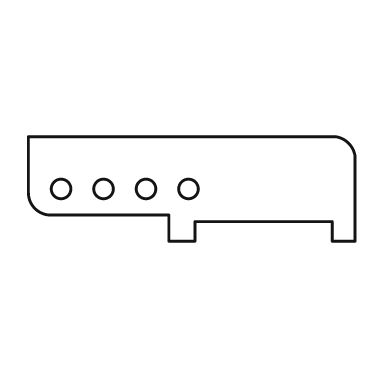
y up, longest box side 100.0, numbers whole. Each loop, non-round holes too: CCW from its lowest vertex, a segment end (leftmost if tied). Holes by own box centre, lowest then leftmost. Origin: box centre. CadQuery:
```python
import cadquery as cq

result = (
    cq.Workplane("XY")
    .moveTo(-7.0, -16.0)
    .lineTo(1.0, -16.0)
    .lineTo(1.0, -10.0)
    .lineTo(43.0, -10.0)
    .lineTo(43.0, -16.0)
    .lineTo(50.0, -16.0)
    .lineTo(50.0, 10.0)
    .threePointArc((48.0, 14.0), (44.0, 16.0))
    .lineTo(-50.0, 16.0)
    .lineTo(-50.0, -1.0)
    .threePointArc((-48.0, -6.0), (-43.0, -8.0))
    .lineTo(-7.0, -8.0)
    .close()
    .moveTo(-40.0, 0.0)
    .circle(3.0)
    .moveTo(-27.0, 0.0)
    .circle(3.0)
    .moveTo(-14.0, 0.0)
    .circle(3.0)
    .moveTo(-1.0, 0.0)
    .circle(3.0)
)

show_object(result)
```